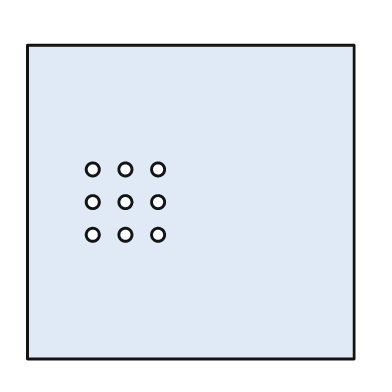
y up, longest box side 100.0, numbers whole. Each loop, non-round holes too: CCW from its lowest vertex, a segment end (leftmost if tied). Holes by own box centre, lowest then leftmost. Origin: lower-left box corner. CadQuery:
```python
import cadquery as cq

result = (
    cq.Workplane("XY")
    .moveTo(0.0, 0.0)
    .lineTo(100.0, 0.0)
    .lineTo(100.0, 96.0)
    .lineTo(0.0, 96.0)
    .close()
    .moveTo(20.0, 38.0)
    .circle(2.0)
    .moveTo(30.0, 38.0)
    .circle(2.0)
    .moveTo(40.0, 38.0)
    .circle(2.0)
    .moveTo(20.0, 48.0)
    .circle(2.0)
    .moveTo(30.0, 48.0)
    .circle(2.0)
    .moveTo(40.0, 48.0)
    .circle(2.0)
    .moveTo(20.0, 58.0)
    .circle(2.0)
    .moveTo(30.0, 58.0)
    .circle(2.0)
    .moveTo(40.0, 58.0)
    .circle(2.0)
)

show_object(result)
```